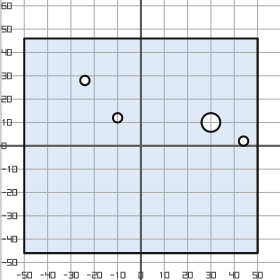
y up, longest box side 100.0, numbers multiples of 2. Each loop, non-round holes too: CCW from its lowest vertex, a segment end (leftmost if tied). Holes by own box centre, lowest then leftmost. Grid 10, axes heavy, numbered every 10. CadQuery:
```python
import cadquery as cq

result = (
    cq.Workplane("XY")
    .moveTo(-50.0, -46.0)
    .lineTo(50.0, -46.0)
    .lineTo(50.0, 46.0)
    .lineTo(-50.0, 46.0)
    .close()
    .moveTo(44.0, 2.0)
    .circle(2.0)
    .moveTo(30.0, 10.0)
    .circle(4.0)
    .moveTo(-10.0, 12.0)
    .circle(2.0)
    .moveTo(-24.0, 28.0)
    .circle(2.0)
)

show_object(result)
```